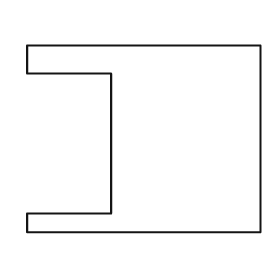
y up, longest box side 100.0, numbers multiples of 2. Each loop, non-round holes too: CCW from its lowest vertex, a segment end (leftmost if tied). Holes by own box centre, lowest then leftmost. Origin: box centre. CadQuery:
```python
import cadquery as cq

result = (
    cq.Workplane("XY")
    .moveTo(-50.0, -40.0)
    .lineTo(50.0, -40.0)
    .lineTo(50.0, 40.0)
    .lineTo(-50.0, 40.0)
    .lineTo(-50.0, 28.0)
    .lineTo(-14.0, 28.0)
    .lineTo(-14.0, -32.0)
    .lineTo(-50.0, -32.0)
    .close()
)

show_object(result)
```